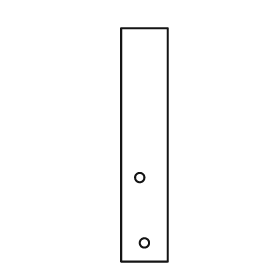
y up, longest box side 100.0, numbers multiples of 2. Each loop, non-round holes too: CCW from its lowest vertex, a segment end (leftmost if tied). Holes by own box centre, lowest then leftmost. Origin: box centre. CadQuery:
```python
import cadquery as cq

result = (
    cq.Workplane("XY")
    .moveTo(-10.0, -50.0)
    .lineTo(10.0, -50.0)
    .lineTo(10.0, 50.0)
    .lineTo(-10.0, 50.0)
    .close()
    .moveTo(0.0, -42.0)
    .circle(2.0)
    .moveTo(-2.0, -14.0)
    .circle(2.0)
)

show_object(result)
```